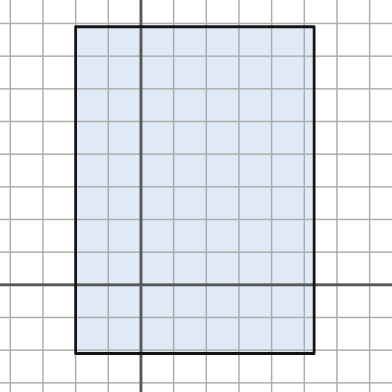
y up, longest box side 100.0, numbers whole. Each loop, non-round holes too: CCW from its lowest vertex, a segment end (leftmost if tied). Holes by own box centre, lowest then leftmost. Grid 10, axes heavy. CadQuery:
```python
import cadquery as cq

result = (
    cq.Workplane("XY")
    .moveTo(-20.0, -21.0)
    .lineTo(53.0, -21.0)
    .lineTo(53.0, 79.0)
    .lineTo(-20.0, 79.0)
    .close()
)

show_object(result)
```